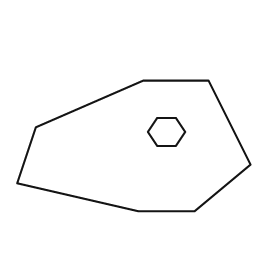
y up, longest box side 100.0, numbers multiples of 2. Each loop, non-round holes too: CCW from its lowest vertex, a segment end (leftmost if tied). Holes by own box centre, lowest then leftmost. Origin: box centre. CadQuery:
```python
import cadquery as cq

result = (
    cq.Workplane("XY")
    .moveTo(2.0, -28.0)
    .lineTo(26.0, -28.0)
    .lineTo(50.0, -8.0)
    .lineTo(32.0, 28.0)
    .lineTo(4.0, 28.0)
    .lineTo(-42.0, 8.0)
    .lineTo(-50.0, -16.0)
    .close()
    .moveTo(10.0, 0.0)
    .lineTo(18.0, 0.0)
    .lineTo(22.0, 6.0)
    .lineTo(18.0, 12.0)
    .lineTo(10.0, 12.0)
    .lineTo(6.0, 6.0)
    .close()
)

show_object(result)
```